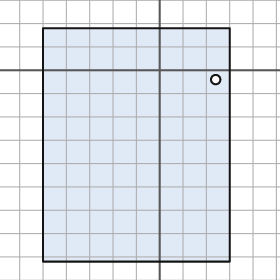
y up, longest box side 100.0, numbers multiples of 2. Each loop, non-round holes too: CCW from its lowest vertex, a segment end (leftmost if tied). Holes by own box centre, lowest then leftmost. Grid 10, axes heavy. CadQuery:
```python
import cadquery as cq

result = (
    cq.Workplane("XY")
    .moveTo(-50.0, -82.0)
    .lineTo(30.0, -82.0)
    .lineTo(30.0, 18.0)
    .lineTo(-50.0, 18.0)
    .close()
    .moveTo(24.0, -4.0)
    .circle(2.0)
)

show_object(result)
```